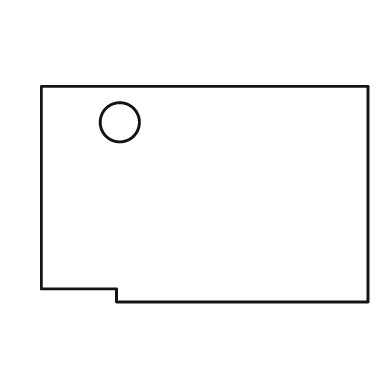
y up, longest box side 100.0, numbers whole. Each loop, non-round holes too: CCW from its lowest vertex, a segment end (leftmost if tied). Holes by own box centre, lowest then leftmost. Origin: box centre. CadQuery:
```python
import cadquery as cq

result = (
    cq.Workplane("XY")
    .moveTo(-27.0, -33.0)
    .lineTo(50.0, -33.0)
    .lineTo(50.0, 33.0)
    .lineTo(-50.0, 33.0)
    .lineTo(-50.0, -29.0)
    .lineTo(-27.0, -29.0)
    .close()
    .moveTo(-26.0, 22.0)
    .circle(6.0)
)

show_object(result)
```